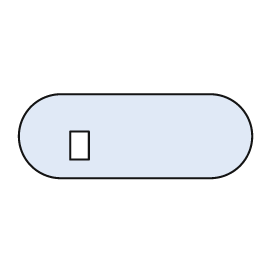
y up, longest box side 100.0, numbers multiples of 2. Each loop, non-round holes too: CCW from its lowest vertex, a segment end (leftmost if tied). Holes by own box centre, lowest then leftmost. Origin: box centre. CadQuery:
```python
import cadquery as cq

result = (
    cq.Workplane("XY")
    .moveTo(-32.0, -18.0)
    .lineTo(32.0, -18.0)
    .threePointArc((50.0, 0.0), (32.0, 18.0))
    .lineTo(-32.0, 18.0)
    .threePointArc((-50.0, 0.0), (-32.0, -18.0))
    .close()
    .moveTo(-28.0, -10.0)
    .lineTo(-20.0, -10.0)
    .lineTo(-20.0, 2.0)
    .lineTo(-28.0, 2.0)
    .close()
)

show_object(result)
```